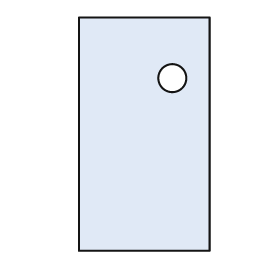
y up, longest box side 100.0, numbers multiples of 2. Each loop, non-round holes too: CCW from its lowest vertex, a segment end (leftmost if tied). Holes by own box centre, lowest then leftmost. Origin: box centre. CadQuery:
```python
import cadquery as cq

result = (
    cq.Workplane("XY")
    .moveTo(-28.0, -50.0)
    .lineTo(28.0, -50.0)
    .lineTo(28.0, 50.0)
    .lineTo(-28.0, 50.0)
    .close()
    .moveTo(12.0, 24.0)
    .circle(6.0)
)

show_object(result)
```